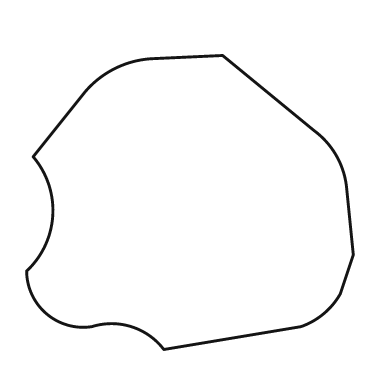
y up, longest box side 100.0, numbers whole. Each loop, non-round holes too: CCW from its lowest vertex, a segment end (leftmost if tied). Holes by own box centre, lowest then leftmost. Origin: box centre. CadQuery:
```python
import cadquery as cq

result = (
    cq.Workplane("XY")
    .moveTo(-8.0, -45.0)
    .lineTo(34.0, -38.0)
    .threePointArc((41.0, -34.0), (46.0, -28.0))
    .lineTo(50.0, -16.0)
    .lineTo(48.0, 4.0)
    .threePointArc((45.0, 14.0), (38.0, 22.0))
    .lineTo(10.0, 45.0)
    .lineTo(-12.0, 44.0)
    .threePointArc((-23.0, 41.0), (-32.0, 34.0))
    .lineTo(-48.0, 14.0)
    .threePointArc((-42.0, -4.0), (-50.0, -21.0))
    .threePointArc((-44.0, -34.0), (-30.0, -38.0))
    .threePointArc((-18.0, -38.0), (-8.0, -45.0))
    .close()
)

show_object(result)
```